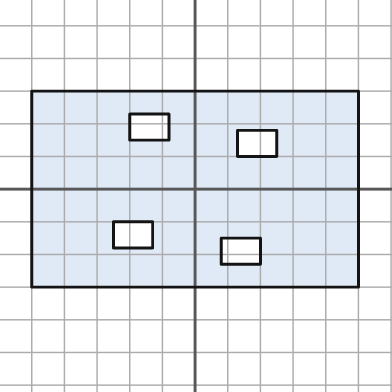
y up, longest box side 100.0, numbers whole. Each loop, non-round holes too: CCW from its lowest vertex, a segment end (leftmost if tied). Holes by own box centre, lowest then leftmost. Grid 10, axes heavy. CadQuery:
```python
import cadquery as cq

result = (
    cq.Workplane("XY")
    .moveTo(-50.0, -30.0)
    .lineTo(50.0, -30.0)
    .lineTo(50.0, 30.0)
    .lineTo(-50.0, 30.0)
    .close()
    .moveTo(8.0, -23.0)
    .lineTo(20.0, -23.0)
    .lineTo(20.0, -15.0)
    .lineTo(8.0, -15.0)
    .close()
    .moveTo(-25.0, -18.0)
    .lineTo(-13.0, -18.0)
    .lineTo(-13.0, -10.0)
    .lineTo(-25.0, -10.0)
    .close()
    .moveTo(13.0, 10.0)
    .lineTo(25.0, 10.0)
    .lineTo(25.0, 18.0)
    .lineTo(13.0, 18.0)
    .close()
    .moveTo(-20.0, 15.0)
    .lineTo(-8.0, 15.0)
    .lineTo(-8.0, 23.0)
    .lineTo(-20.0, 23.0)
    .close()
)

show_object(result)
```